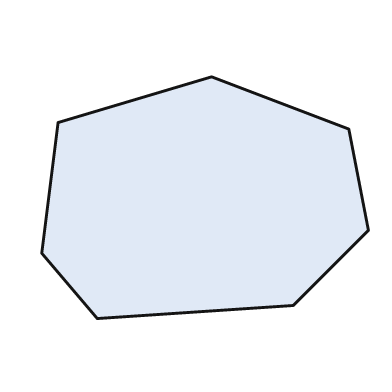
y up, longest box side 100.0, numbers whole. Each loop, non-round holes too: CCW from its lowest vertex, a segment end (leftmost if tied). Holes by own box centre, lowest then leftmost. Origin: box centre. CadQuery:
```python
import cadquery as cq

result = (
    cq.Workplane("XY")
    .moveTo(-33.0, -37.0)
    .lineTo(27.0, -33.0)
    .lineTo(50.0, -10.0)
    .lineTo(44.0, 21.0)
    .lineTo(2.0, 37.0)
    .lineTo(-45.0, 23.0)
    .lineTo(-50.0, -17.0)
    .close()
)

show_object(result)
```